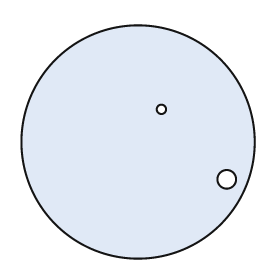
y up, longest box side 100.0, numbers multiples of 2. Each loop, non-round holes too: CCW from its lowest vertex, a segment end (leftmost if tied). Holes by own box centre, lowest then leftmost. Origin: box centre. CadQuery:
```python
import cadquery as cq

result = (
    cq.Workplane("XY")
    .moveTo(0.0, 0.0)
    .circle(50.0)
    .moveTo(38.0, -16.0)
    .circle(4.0)
    .moveTo(10.0, 14.0)
    .circle(2.0)
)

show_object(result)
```